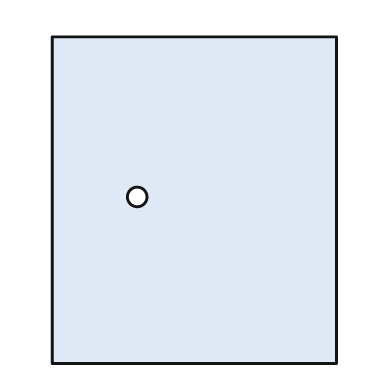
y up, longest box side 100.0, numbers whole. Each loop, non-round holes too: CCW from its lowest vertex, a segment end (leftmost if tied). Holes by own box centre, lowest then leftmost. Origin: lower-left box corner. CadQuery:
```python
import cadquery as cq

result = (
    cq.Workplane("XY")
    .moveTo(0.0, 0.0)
    .lineTo(87.0, 0.0)
    .lineTo(87.0, 100.0)
    .lineTo(0.0, 100.0)
    .close()
    .moveTo(26.0, 51.0)
    .circle(3.0)
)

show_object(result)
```